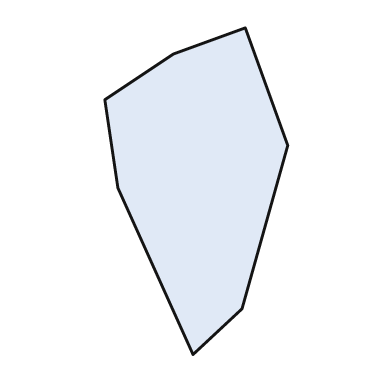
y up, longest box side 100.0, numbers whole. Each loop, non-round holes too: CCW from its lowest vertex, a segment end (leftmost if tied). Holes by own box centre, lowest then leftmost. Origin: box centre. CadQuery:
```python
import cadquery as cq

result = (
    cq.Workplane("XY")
    .moveTo(-1.0, -50.0)
    .lineTo(14.0, -36.0)
    .lineTo(28.0, 14.0)
    .lineTo(15.0, 50.0)
    .lineTo(-7.0, 42.0)
    .lineTo(-28.0, 28.0)
    .lineTo(-24.0, 1.0)
    .close()
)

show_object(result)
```